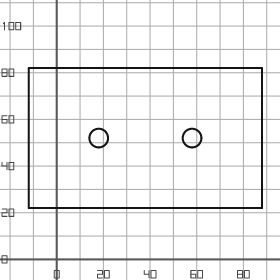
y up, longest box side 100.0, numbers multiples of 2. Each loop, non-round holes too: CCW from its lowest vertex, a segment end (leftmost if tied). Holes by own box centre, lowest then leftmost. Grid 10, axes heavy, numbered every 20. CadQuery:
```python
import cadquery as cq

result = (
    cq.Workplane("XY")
    .moveTo(-12.0, 22.0)
    .lineTo(88.0, 22.0)
    .lineTo(88.0, 82.0)
    .lineTo(-12.0, 82.0)
    .close()
    .moveTo(18.0, 52.0)
    .circle(4.0)
    .moveTo(58.0, 52.0)
    .circle(4.0)
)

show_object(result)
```